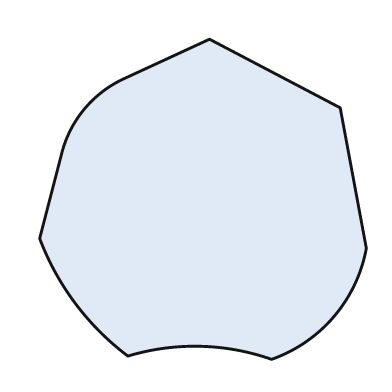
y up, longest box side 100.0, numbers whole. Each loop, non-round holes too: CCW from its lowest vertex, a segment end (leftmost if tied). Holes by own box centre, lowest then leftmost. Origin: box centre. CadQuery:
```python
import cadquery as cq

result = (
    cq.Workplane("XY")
    .moveTo(21.0, -49.0)
    .threePointArc((40.0, -36.0), (50.0, -15.0))
    .lineTo(42.0, 28.0)
    .lineTo(2.0, 49.0)
    .lineTo(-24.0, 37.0)
    .threePointArc((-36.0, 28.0), (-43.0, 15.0))
    .lineTo(-50.0, -12.0)
    .threePointArc((-39.0, -32.0), (-23.0, -48.0))
    .threePointArc((-1.0, -45.0), (21.0, -49.0))
    .close()
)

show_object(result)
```